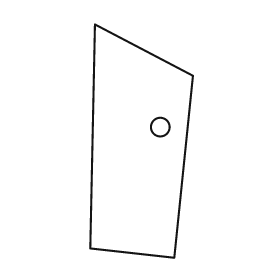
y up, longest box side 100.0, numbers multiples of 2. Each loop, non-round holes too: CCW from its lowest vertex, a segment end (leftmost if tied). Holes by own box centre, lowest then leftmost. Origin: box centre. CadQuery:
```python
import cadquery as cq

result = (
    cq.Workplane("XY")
    .moveTo(14.0, -50.0)
    .lineTo(22.0, 28.0)
    .lineTo(-20.0, 50.0)
    .lineTo(-22.0, -46.0)
    .close()
    .moveTo(8.0, 6.0)
    .circle(4.0)
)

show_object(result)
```